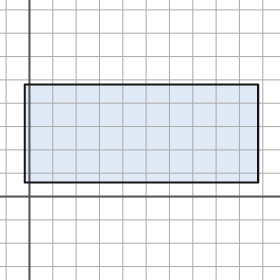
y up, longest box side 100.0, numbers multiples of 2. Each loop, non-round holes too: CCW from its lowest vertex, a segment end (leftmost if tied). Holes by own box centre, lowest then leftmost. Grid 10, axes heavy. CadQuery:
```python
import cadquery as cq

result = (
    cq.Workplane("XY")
    .moveTo(-2.0, 6.0)
    .lineTo(98.0, 6.0)
    .lineTo(98.0, 48.0)
    .lineTo(-2.0, 48.0)
    .close()
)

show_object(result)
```